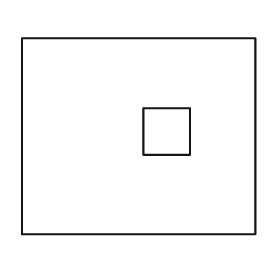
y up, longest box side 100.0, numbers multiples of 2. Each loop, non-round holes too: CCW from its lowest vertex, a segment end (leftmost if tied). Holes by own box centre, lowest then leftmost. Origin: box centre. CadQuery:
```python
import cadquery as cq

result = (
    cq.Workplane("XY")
    .moveTo(-50.0, -42.0)
    .lineTo(50.0, -42.0)
    .lineTo(50.0, 42.0)
    .lineTo(-50.0, 42.0)
    .close()
    .moveTo(2.0, -8.0)
    .lineTo(22.0, -8.0)
    .lineTo(22.0, 12.0)
    .lineTo(2.0, 12.0)
    .close()
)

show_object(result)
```